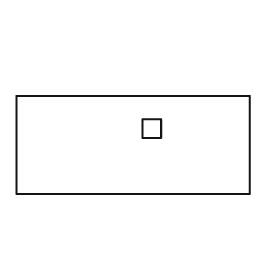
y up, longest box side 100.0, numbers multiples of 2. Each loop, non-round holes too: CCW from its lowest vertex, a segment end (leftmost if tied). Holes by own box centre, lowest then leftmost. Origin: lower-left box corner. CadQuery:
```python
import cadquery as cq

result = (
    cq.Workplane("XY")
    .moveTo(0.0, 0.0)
    .lineTo(100.0, 0.0)
    .lineTo(100.0, 42.0)
    .lineTo(0.0, 42.0)
    .close()
    .moveTo(54.0, 24.0)
    .lineTo(62.0, 24.0)
    .lineTo(62.0, 32.0)
    .lineTo(54.0, 32.0)
    .close()
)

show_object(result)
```